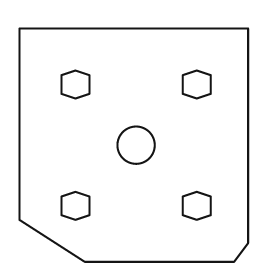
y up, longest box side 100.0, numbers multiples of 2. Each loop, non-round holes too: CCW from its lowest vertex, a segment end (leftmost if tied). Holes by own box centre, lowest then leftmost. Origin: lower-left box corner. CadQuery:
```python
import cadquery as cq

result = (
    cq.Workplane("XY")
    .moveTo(28.0, 0.0)
    .lineTo(92.0, 0.0)
    .lineTo(98.0, 8.0)
    .lineTo(98.0, 100.0)
    .lineTo(0.0, 100.0)
    .lineTo(0.0, 18.0)
    .close()
    .moveTo(24.0, 18.0)
    .lineTo(30.0, 20.0)
    .lineTo(30.0, 28.0)
    .lineTo(24.0, 30.0)
    .lineTo(18.0, 28.0)
    .lineTo(18.0, 20.0)
    .close()
    .moveTo(76.0, 18.0)
    .lineTo(82.0, 20.0)
    .lineTo(82.0, 28.0)
    .lineTo(76.0, 30.0)
    .lineTo(70.0, 28.0)
    .lineTo(70.0, 20.0)
    .close()
    .moveTo(50.0, 50.0)
    .circle(8.0)
    .moveTo(24.0, 70.0)
    .lineTo(30.0, 72.0)
    .lineTo(30.0, 80.0)
    .lineTo(24.0, 82.0)
    .lineTo(18.0, 80.0)
    .lineTo(18.0, 72.0)
    .close()
    .moveTo(76.0, 70.0)
    .lineTo(82.0, 72.0)
    .lineTo(82.0, 80.0)
    .lineTo(76.0, 82.0)
    .lineTo(70.0, 80.0)
    .lineTo(70.0, 72.0)
    .close()
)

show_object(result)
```